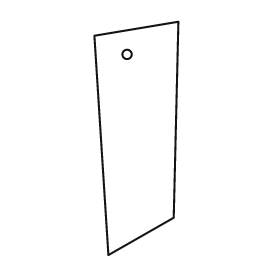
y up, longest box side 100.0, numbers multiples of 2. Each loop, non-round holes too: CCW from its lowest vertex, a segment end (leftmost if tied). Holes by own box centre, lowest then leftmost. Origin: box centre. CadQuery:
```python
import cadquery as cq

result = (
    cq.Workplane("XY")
    .moveTo(-12.0, -50.0)
    .lineTo(16.0, -34.0)
    .lineTo(18.0, 50.0)
    .lineTo(-18.0, 44.0)
    .close()
    .moveTo(-4.0, 36.0)
    .circle(2.0)
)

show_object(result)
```